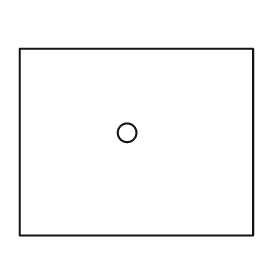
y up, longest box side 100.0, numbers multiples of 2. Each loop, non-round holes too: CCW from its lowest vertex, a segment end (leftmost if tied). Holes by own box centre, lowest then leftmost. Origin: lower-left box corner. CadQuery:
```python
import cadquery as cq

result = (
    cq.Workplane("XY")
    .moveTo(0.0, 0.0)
    .lineTo(100.0, 0.0)
    .lineTo(100.0, 80.0)
    .lineTo(0.0, 80.0)
    .close()
    .moveTo(46.0, 44.0)
    .circle(4.0)
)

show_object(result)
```